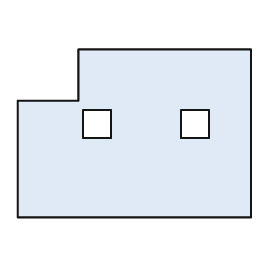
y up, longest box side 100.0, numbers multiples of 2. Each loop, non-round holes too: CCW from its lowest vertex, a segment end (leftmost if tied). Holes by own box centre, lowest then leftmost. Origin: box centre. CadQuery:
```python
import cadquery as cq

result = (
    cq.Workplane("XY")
    .moveTo(-50.0, -36.0)
    .lineTo(50.0, -36.0)
    .lineTo(50.0, 36.0)
    .lineTo(-24.0, 36.0)
    .lineTo(-24.0, 14.0)
    .lineTo(-50.0, 14.0)
    .close()
    .moveTo(-22.0, -2.0)
    .lineTo(-10.0, -2.0)
    .lineTo(-10.0, 10.0)
    .lineTo(-22.0, 10.0)
    .close()
    .moveTo(20.0, -2.0)
    .lineTo(32.0, -2.0)
    .lineTo(32.0, 10.0)
    .lineTo(20.0, 10.0)
    .close()
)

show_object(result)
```